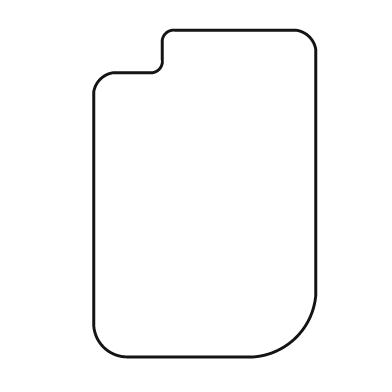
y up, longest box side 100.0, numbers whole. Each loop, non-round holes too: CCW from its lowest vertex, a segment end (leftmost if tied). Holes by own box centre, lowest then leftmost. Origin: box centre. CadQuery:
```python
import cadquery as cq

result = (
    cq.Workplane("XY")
    .moveTo(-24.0, -50.0)
    .lineTo(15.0, -50.0)
    .threePointArc((28.0, -44.0), (34.0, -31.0))
    .lineTo(34.0, 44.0)
    .threePointArc((32.0, 48.0), (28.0, 50.0))
    .lineTo(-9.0, 50.0)
    .threePointArc((-12.0, 49.0), (-13.0, 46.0))
    .lineTo(-13.0, 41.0)
    .threePointArc((-14.0, 38.0), (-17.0, 37.0))
    .lineTo(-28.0, 37.0)
    .threePointArc((-32.0, 35.0), (-34.0, 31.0))
    .lineTo(-34.0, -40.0)
    .threePointArc((-31.0, -47.0), (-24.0, -50.0))
    .close()
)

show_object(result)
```